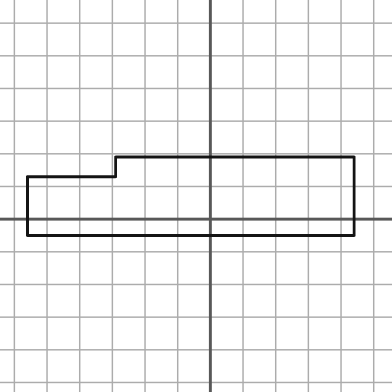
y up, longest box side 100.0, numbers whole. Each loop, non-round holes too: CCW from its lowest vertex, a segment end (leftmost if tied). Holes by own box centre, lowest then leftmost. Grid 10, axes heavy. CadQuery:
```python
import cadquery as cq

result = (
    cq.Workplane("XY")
    .moveTo(-56.0, -5.0)
    .lineTo(44.0, -5.0)
    .lineTo(44.0, 19.0)
    .lineTo(-29.0, 19.0)
    .lineTo(-29.0, 13.0)
    .lineTo(-56.0, 13.0)
    .close()
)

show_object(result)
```